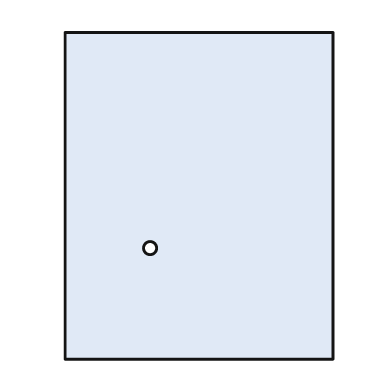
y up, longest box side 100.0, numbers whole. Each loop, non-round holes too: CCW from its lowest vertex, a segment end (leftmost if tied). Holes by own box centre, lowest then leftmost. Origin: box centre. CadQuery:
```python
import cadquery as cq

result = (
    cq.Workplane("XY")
    .moveTo(-41.0, -50.0)
    .lineTo(41.0, -50.0)
    .lineTo(41.0, 50.0)
    .lineTo(-41.0, 50.0)
    .close()
    .moveTo(-15.0, -16.0)
    .circle(2.0)
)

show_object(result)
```